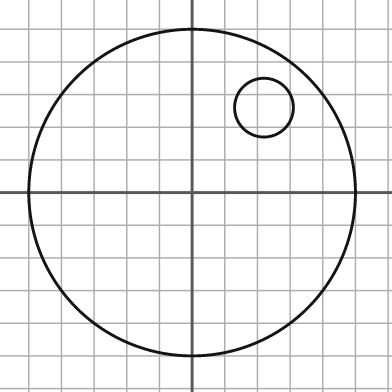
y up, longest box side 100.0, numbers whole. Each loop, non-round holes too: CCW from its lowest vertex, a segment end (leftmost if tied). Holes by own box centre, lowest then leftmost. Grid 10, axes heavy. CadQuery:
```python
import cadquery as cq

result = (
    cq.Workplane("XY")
    .moveTo(0.0, 0.0)
    .circle(50.0)
    .moveTo(22.0, 26.0)
    .circle(9.0)
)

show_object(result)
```